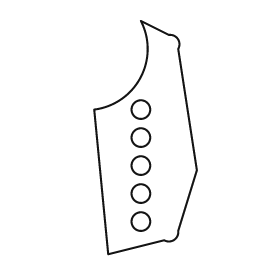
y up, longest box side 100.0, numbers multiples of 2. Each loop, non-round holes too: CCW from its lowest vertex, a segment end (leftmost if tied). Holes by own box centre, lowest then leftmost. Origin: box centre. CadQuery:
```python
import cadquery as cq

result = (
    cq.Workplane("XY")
    .moveTo(-16.0, -50.0)
    .lineTo(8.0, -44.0)
    .threePointArc((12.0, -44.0), (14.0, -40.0))
    .lineTo(22.0, -14.0)
    .lineTo(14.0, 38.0)
    .threePointArc((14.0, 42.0), (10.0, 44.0))
    .lineTo(-2.0, 50.0)
    .threePointArc((-2.0, 26.0), (-22.0, 12.0))
    .close()
    .moveTo(-2.0, -36.0)
    .circle(4.0)
    .moveTo(-2.0, -24.0)
    .circle(4.0)
    .moveTo(-2.0, -12.0)
    .circle(4.0)
    .moveTo(-2.0, 0.0)
    .circle(4.0)
    .moveTo(-2.0, 12.0)
    .circle(4.0)
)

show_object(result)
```